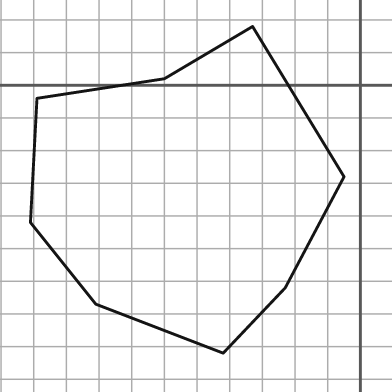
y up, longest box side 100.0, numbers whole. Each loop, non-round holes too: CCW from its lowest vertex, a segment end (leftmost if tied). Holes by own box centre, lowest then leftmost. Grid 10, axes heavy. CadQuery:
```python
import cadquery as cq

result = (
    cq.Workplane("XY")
    .moveTo(-42.0, -82.0)
    .lineTo(-23.0, -62.0)
    .lineTo(-5.0, -28.0)
    .lineTo(-33.0, 18.0)
    .lineTo(-60.0, 2.0)
    .lineTo(-99.0, -4.0)
    .lineTo(-101.0, -42.0)
    .lineTo(-81.0, -67.0)
    .close()
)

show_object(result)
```